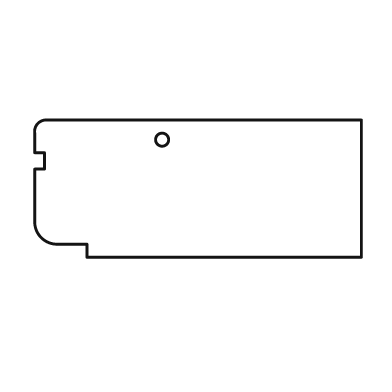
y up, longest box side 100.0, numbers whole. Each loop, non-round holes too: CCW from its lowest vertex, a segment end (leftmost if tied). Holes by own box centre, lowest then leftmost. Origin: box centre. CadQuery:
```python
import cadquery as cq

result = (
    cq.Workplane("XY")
    .moveTo(-34.0, -21.0)
    .lineTo(50.0, -21.0)
    .lineTo(50.0, 21.0)
    .lineTo(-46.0, 21.0)
    .threePointArc((-49.0, 20.0), (-50.0, 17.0))
    .lineTo(-50.0, 11.0)
    .lineTo(-47.0, 11.0)
    .lineTo(-47.0, 6.0)
    .lineTo(-50.0, 6.0)
    .lineTo(-50.0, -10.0)
    .threePointArc((-48.0, -15.0), (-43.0, -17.0))
    .lineTo(-34.0, -17.0)
    .close()
    .moveTo(-11.0, 15.0)
    .circle(2.0)
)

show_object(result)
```